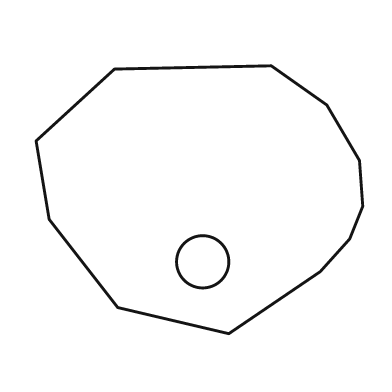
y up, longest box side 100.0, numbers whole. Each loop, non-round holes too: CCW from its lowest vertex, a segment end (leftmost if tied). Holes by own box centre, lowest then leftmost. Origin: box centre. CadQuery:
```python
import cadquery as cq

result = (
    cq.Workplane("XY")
    .moveTo(9.0, -41.0)
    .lineTo(37.0, -22.0)
    .lineTo(46.0, -12.0)
    .lineTo(50.0, -2.0)
    .lineTo(49.0, 12.0)
    .lineTo(39.0, 29.0)
    .lineTo(22.0, 41.0)
    .lineTo(-26.0, 40.0)
    .lineTo(-50.0, 18.0)
    .lineTo(-46.0, -6.0)
    .lineTo(-25.0, -33.0)
    .close()
    .moveTo(1.0, -19.0)
    .circle(8.0)
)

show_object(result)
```